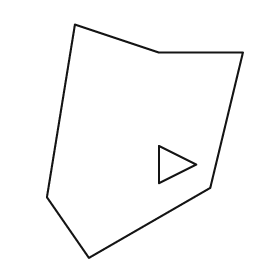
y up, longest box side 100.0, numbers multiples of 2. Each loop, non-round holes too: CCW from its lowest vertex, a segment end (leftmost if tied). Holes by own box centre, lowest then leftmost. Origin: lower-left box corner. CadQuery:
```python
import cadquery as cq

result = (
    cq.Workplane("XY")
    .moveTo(18.0, 0.0)
    .lineTo(70.0, 30.0)
    .lineTo(84.0, 88.0)
    .lineTo(48.0, 88.0)
    .lineTo(12.0, 100.0)
    .lineTo(0.0, 26.0)
    .close()
    .moveTo(48.0, 32.0)
    .lineTo(64.0, 40.0)
    .lineTo(48.0, 48.0)
    .close()
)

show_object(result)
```